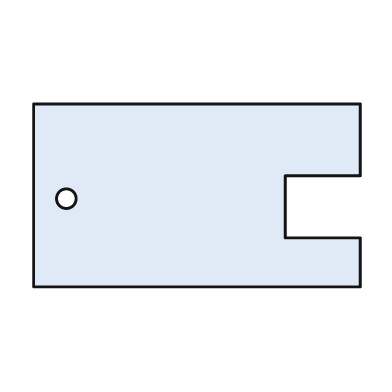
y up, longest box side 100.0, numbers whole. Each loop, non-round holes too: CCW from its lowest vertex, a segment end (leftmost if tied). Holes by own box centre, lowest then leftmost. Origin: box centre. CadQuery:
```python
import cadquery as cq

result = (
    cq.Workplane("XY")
    .moveTo(-50.0, -28.0)
    .lineTo(50.0, -28.0)
    .lineTo(50.0, -13.0)
    .lineTo(27.0, -13.0)
    .lineTo(27.0, 6.0)
    .lineTo(50.0, 6.0)
    .lineTo(50.0, 28.0)
    .lineTo(-50.0, 28.0)
    .close()
    .moveTo(-40.0, -1.0)
    .circle(3.0)
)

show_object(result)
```